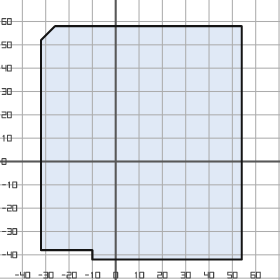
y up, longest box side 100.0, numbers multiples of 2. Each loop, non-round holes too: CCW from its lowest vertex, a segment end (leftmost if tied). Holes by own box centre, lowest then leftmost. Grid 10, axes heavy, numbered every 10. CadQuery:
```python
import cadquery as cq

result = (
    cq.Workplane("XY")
    .moveTo(-10.0, -42.0)
    .lineTo(54.0, -42.0)
    .lineTo(54.0, 58.0)
    .lineTo(-26.0, 58.0)
    .lineTo(-32.0, 52.0)
    .lineTo(-32.0, -38.0)
    .lineTo(-10.0, -38.0)
    .close()
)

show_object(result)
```